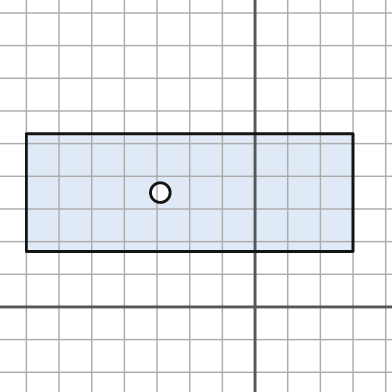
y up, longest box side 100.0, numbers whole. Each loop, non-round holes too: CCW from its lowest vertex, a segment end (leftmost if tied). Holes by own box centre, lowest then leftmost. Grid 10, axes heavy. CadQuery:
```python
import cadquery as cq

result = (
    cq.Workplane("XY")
    .moveTo(-70.0, 17.0)
    .lineTo(30.0, 17.0)
    .lineTo(30.0, 53.0)
    .lineTo(-70.0, 53.0)
    .close()
    .moveTo(-29.0, 35.0)
    .circle(3.0)
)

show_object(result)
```